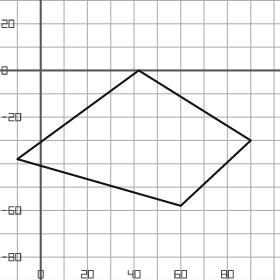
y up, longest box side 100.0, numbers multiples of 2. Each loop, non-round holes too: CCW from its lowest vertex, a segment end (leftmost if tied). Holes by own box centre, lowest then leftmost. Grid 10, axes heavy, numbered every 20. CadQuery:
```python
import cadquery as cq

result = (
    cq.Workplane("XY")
    .moveTo(60.0, -58.0)
    .lineTo(90.0, -30.0)
    .lineTo(42.0, 0.0)
    .lineTo(-10.0, -38.0)
    .close()
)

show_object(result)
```